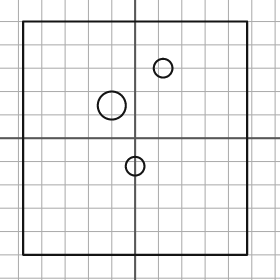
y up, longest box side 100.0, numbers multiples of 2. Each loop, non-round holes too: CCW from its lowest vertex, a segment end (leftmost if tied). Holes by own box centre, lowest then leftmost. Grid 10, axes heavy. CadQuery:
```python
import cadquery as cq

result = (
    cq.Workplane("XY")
    .moveTo(-48.0, -50.0)
    .lineTo(48.0, -50.0)
    .lineTo(48.0, 50.0)
    .lineTo(-48.0, 50.0)
    .close()
    .moveTo(0.0, -12.0)
    .circle(4.0)
    .moveTo(-10.0, 14.0)
    .circle(6.0)
    .moveTo(12.0, 30.0)
    .circle(4.0)
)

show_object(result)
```